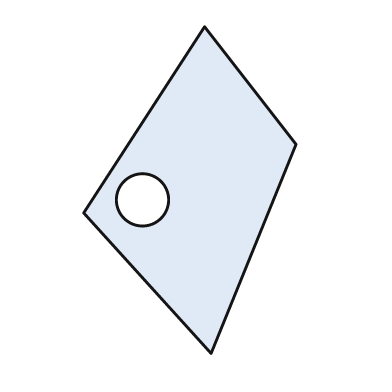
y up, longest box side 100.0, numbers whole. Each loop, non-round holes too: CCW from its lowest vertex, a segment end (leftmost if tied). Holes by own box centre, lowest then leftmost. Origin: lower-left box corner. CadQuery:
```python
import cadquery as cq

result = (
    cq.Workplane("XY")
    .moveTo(39.0, 0.0)
    .lineTo(65.0, 64.0)
    .lineTo(37.0, 100.0)
    .lineTo(0.0, 43.0)
    .close()
    .moveTo(18.0, 47.0)
    .circle(8.0)
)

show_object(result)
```